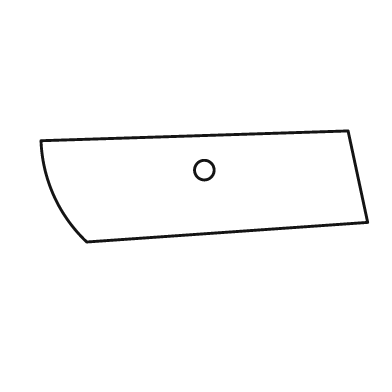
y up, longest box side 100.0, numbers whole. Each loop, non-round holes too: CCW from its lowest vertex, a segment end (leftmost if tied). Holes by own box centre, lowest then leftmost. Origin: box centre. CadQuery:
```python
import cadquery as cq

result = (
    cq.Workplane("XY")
    .moveTo(-36.0, -17.0)
    .lineTo(50.0, -11.0)
    .lineTo(44.0, 17.0)
    .lineTo(-50.0, 14.0)
    .threePointArc((-46.0, -3.0), (-36.0, -17.0))
    .close()
    .moveTo(0.0, 5.0)
    .circle(3.0)
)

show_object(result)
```